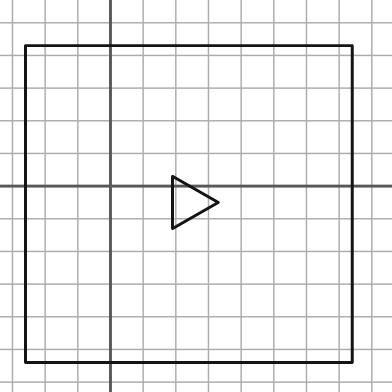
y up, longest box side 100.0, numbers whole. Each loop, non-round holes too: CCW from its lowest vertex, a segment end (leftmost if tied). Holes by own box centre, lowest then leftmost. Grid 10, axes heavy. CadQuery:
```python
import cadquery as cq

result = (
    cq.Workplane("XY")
    .moveTo(-26.0, -54.0)
    .lineTo(74.0, -54.0)
    .lineTo(74.0, 43.0)
    .lineTo(-26.0, 43.0)
    .close()
    .moveTo(19.0, -13.0)
    .lineTo(33.0, -5.0)
    .lineTo(19.0, 3.0)
    .close()
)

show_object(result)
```